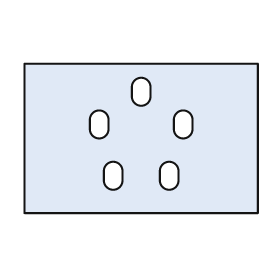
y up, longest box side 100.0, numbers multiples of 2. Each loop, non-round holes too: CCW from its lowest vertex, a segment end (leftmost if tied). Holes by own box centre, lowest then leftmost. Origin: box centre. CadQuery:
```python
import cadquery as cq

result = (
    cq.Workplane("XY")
    .moveTo(-50.0, -32.0)
    .lineTo(50.0, -32.0)
    .lineTo(50.0, 32.0)
    .lineTo(-50.0, 32.0)
    .close()
    .moveTo(-16.0, -18.0)
    .threePointArc((-12.0, -22.0), (-8.0, -18.0))
    .lineTo(-8.0, -14.0)
    .threePointArc((-12.0, -10.0), (-16.0, -14.0))
    .close()
    .moveTo(8.0, -18.0)
    .threePointArc((12.0, -22.0), (16.0, -18.0))
    .lineTo(16.0, -14.0)
    .threePointArc((12.0, -10.0), (8.0, -14.0))
    .close()
    .moveTo(-22.0, 4.0)
    .threePointArc((-18.0, 0.0), (-14.0, 4.0))
    .lineTo(-14.0, 8.0)
    .threePointArc((-18.0, 12.0), (-22.0, 8.0))
    .close()
    .moveTo(14.0, 4.0)
    .threePointArc((18.0, 0.0), (22.0, 4.0))
    .lineTo(22.0, 8.0)
    .threePointArc((18.0, 12.0), (14.0, 8.0))
    .close()
    .moveTo(-4.0, 18.0)
    .threePointArc((0.0, 14.0), (4.0, 18.0))
    .lineTo(4.0, 22.0)
    .threePointArc((0.0, 26.0), (-4.0, 22.0))
    .close()
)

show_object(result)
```